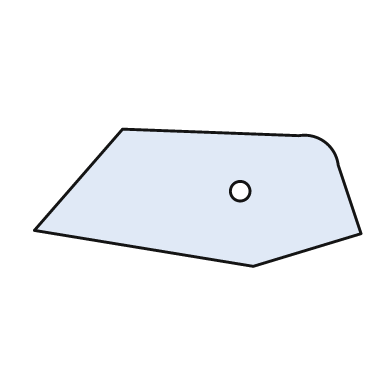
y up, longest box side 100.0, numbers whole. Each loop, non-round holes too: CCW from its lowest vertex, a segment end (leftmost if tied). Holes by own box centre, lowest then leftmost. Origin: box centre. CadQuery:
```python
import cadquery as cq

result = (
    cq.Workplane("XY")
    .moveTo(17.0, -21.0)
    .lineTo(50.0, -11.0)
    .lineTo(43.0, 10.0)
    .threePointArc((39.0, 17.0), (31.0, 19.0))
    .lineTo(-23.0, 21.0)
    .lineTo(-50.0, -10.0)
    .close()
    .moveTo(13.0, 2.0)
    .circle(3.0)
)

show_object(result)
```